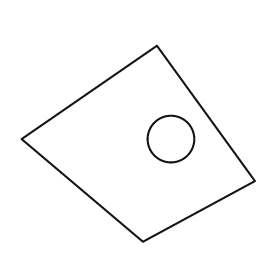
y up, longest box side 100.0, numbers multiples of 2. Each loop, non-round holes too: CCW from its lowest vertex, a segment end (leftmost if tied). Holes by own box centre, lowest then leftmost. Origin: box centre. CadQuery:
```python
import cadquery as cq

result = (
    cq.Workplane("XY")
    .moveTo(2.0, -42.0)
    .lineTo(50.0, -16.0)
    .lineTo(8.0, 42.0)
    .lineTo(-50.0, 2.0)
    .close()
    .moveTo(14.0, 2.0)
    .circle(10.0)
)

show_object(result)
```